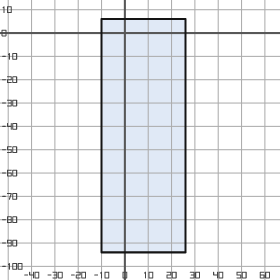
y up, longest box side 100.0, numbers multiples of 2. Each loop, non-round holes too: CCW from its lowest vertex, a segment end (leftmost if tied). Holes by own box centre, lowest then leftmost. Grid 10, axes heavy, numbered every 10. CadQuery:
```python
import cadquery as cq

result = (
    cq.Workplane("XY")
    .moveTo(-10.0, -94.0)
    .lineTo(26.0, -94.0)
    .lineTo(26.0, 6.0)
    .lineTo(-10.0, 6.0)
    .close()
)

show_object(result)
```